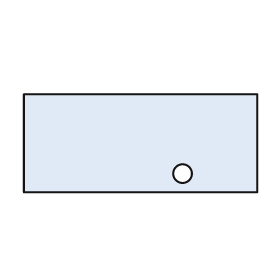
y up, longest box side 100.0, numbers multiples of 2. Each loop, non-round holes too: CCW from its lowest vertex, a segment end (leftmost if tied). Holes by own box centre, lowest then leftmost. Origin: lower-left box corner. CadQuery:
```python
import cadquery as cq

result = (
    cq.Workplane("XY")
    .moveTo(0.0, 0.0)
    .lineTo(100.0, 0.0)
    .lineTo(100.0, 42.0)
    .lineTo(0.0, 42.0)
    .close()
    .moveTo(68.0, 8.0)
    .circle(4.0)
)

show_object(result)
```